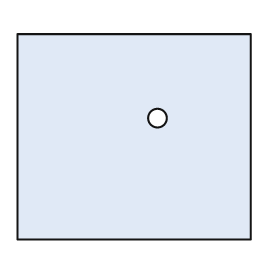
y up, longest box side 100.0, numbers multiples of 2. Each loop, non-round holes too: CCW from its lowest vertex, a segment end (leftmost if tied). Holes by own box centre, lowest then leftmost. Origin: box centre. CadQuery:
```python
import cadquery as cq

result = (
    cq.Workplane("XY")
    .moveTo(-50.0, -44.0)
    .lineTo(50.0, -44.0)
    .lineTo(50.0, 44.0)
    .lineTo(-50.0, 44.0)
    .close()
    .moveTo(10.0, 8.0)
    .circle(4.0)
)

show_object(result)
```